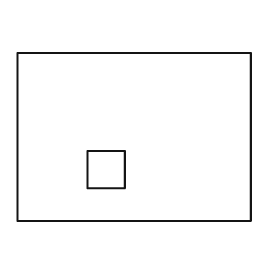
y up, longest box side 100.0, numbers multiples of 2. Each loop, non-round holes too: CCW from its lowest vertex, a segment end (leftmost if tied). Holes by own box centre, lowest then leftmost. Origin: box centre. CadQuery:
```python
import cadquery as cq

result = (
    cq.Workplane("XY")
    .moveTo(-50.0, -36.0)
    .lineTo(50.0, -36.0)
    .lineTo(50.0, 36.0)
    .lineTo(-50.0, 36.0)
    .close()
    .moveTo(-20.0, -22.0)
    .lineTo(-4.0, -22.0)
    .lineTo(-4.0, -6.0)
    .lineTo(-20.0, -6.0)
    .close()
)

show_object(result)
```